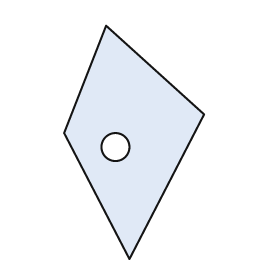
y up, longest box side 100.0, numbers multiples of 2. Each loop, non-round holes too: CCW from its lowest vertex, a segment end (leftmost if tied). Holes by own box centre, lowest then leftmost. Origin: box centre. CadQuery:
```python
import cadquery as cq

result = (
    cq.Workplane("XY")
    .moveTo(-2.0, -50.0)
    .lineTo(30.0, 12.0)
    .lineTo(-12.0, 50.0)
    .lineTo(-30.0, 4.0)
    .close()
    .moveTo(-8.0, -2.0)
    .circle(6.0)
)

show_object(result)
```